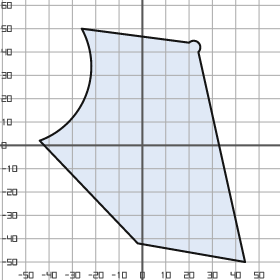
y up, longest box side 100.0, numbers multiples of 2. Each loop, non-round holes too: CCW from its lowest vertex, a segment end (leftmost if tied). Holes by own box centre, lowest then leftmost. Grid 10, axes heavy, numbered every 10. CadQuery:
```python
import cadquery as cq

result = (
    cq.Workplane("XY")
    .moveTo(44.0, -50.0)
    .lineTo(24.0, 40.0)
    .threePointArc((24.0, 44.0), (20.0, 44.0))
    .lineTo(-26.0, 50.0)
    .threePointArc((-24.0, 22.0), (-44.0, 2.0))
    .lineTo(-2.0, -42.0)
    .close()
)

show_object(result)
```